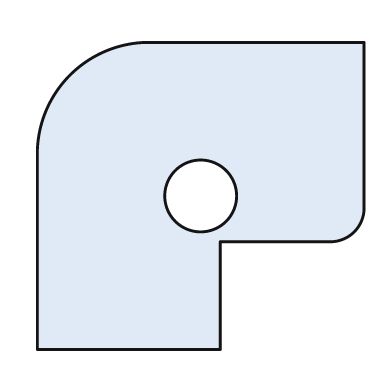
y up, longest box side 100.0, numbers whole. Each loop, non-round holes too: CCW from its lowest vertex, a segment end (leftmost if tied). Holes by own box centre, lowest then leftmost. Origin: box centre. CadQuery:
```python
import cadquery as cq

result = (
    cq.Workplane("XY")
    .moveTo(-50.0, -47.0)
    .lineTo(6.0, -47.0)
    .lineTo(6.0, -14.0)
    .lineTo(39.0, -14.0)
    .threePointArc((47.0, -11.0), (50.0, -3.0))
    .lineTo(50.0, 47.0)
    .lineTo(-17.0, 47.0)
    .threePointArc((-40.0, 37.0), (-50.0, 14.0))
    .close()
    .moveTo(0.0, 0.0)
    .circle(11.0)
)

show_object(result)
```